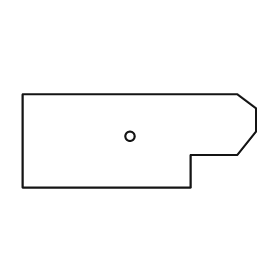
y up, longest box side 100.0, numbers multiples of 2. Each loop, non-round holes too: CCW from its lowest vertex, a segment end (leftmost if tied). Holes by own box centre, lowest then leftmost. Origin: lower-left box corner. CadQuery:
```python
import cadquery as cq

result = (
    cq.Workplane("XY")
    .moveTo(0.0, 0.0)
    .lineTo(72.0, 0.0)
    .lineTo(72.0, 14.0)
    .lineTo(92.0, 14.0)
    .lineTo(100.0, 24.0)
    .lineTo(100.0, 34.0)
    .lineTo(92.0, 40.0)
    .lineTo(0.0, 40.0)
    .close()
    .moveTo(46.0, 22.0)
    .circle(2.0)
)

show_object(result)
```